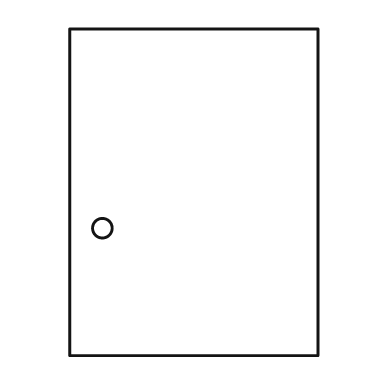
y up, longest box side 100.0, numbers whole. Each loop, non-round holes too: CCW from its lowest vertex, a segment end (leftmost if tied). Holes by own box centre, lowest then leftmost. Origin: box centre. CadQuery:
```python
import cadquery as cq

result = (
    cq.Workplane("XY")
    .moveTo(-38.0, -50.0)
    .lineTo(38.0, -50.0)
    .lineTo(38.0, 50.0)
    .lineTo(-38.0, 50.0)
    .close()
    .moveTo(-28.0, -11.0)
    .circle(3.0)
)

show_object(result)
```